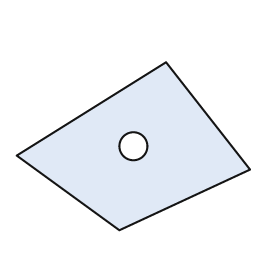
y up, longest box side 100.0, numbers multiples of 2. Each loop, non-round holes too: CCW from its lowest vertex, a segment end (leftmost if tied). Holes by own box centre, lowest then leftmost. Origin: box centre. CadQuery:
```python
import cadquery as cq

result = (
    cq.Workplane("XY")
    .moveTo(-6.0, -36.0)
    .lineTo(50.0, -10.0)
    .lineTo(14.0, 36.0)
    .lineTo(-50.0, -4.0)
    .close()
    .moveTo(0.0, 0.0)
    .circle(6.0)
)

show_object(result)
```